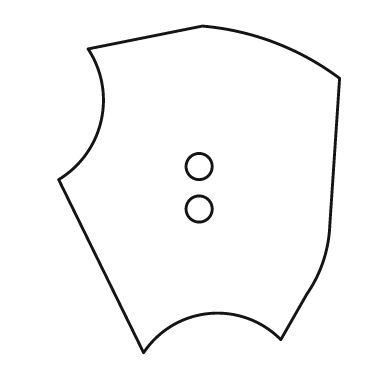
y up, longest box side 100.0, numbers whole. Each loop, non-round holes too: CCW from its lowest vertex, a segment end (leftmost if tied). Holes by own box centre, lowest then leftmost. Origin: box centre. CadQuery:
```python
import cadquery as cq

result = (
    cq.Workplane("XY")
    .moveTo(-17.0, -50.0)
    .threePointArc((3.0, -38.0), (25.0, -46.0))
    .lineTo(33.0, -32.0)
    .threePointArc((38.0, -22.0), (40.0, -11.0))
    .lineTo(43.0, 34.0)
    .threePointArc((23.0, 45.0), (1.0, 50.0))
    .lineTo(-34.0, 43.0)
    .threePointArc((-30.0, 21.0), (-43.0, 3.0))
    .close()
    .moveTo(0.0, -6.0)
    .circle(4.0)
    .moveTo(0.0, 7.0)
    .circle(4.0)
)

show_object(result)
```